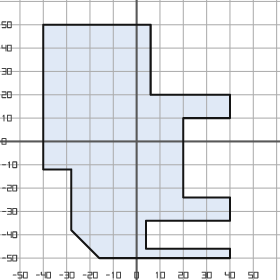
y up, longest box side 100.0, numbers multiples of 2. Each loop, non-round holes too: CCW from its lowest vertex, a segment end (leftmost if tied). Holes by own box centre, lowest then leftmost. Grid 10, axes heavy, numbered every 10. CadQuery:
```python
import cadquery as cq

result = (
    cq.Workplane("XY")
    .moveTo(-16.0, -50.0)
    .lineTo(40.0, -50.0)
    .lineTo(40.0, -46.0)
    .lineTo(4.0, -46.0)
    .lineTo(4.0, -34.0)
    .lineTo(40.0, -34.0)
    .lineTo(40.0, -24.0)
    .lineTo(20.0, -24.0)
    .lineTo(20.0, 10.0)
    .lineTo(40.0, 10.0)
    .lineTo(40.0, 20.0)
    .lineTo(6.0, 20.0)
    .lineTo(6.0, 50.0)
    .lineTo(-40.0, 50.0)
    .lineTo(-40.0, -12.0)
    .lineTo(-28.0, -12.0)
    .lineTo(-28.0, -38.0)
    .close()
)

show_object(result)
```